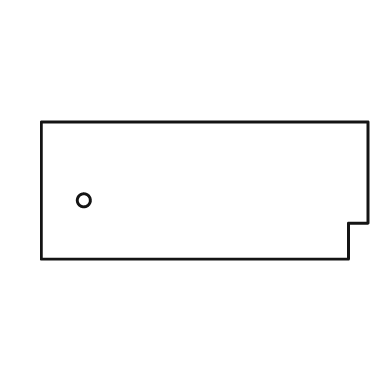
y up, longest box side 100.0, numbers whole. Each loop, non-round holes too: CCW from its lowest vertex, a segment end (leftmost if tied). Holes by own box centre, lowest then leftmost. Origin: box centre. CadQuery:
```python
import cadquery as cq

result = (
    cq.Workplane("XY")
    .moveTo(-50.0, -21.0)
    .lineTo(44.0, -21.0)
    .lineTo(44.0, -10.0)
    .lineTo(50.0, -10.0)
    .lineTo(50.0, 21.0)
    .lineTo(-50.0, 21.0)
    .close()
    .moveTo(-37.0, -3.0)
    .circle(2.0)
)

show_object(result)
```